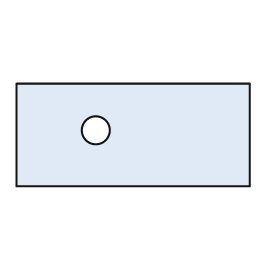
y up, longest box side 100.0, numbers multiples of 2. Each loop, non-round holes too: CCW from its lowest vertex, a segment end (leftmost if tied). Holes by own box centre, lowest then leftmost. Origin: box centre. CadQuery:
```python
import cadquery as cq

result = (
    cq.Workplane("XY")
    .moveTo(-50.0, -22.0)
    .lineTo(50.0, -22.0)
    .lineTo(50.0, 22.0)
    .lineTo(-50.0, 22.0)
    .close()
    .moveTo(-16.0, 2.0)
    .circle(6.0)
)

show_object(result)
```